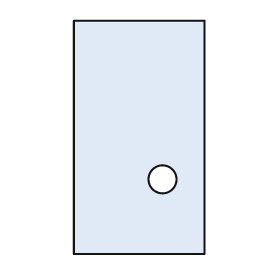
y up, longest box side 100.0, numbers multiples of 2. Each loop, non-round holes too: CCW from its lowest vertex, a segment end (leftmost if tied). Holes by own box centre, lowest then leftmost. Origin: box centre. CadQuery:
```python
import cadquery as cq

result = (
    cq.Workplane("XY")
    .moveTo(-28.0, -50.0)
    .lineTo(28.0, -50.0)
    .lineTo(28.0, 50.0)
    .lineTo(-28.0, 50.0)
    .close()
    .moveTo(10.0, -18.0)
    .circle(6.0)
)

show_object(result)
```